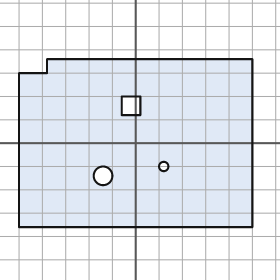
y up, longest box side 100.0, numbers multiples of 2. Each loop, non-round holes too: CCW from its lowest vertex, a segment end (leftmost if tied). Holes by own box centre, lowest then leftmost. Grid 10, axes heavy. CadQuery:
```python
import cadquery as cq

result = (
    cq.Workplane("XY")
    .moveTo(-50.0, -36.0)
    .lineTo(50.0, -36.0)
    .lineTo(50.0, 36.0)
    .lineTo(-38.0, 36.0)
    .lineTo(-38.0, 30.0)
    .lineTo(-50.0, 30.0)
    .close()
    .moveTo(-14.0, -14.0)
    .circle(4.0)
    .moveTo(12.0, -10.0)
    .circle(2.0)
    .moveTo(-6.0, 12.0)
    .lineTo(2.0, 12.0)
    .lineTo(2.0, 20.0)
    .lineTo(-6.0, 20.0)
    .close()
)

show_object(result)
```